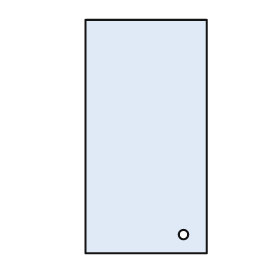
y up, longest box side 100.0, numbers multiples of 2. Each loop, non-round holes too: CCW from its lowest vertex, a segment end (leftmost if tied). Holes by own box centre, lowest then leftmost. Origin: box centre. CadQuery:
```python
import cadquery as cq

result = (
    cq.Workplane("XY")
    .moveTo(-26.0, -50.0)
    .lineTo(26.0, -50.0)
    .lineTo(26.0, 50.0)
    .lineTo(-26.0, 50.0)
    .close()
    .moveTo(16.0, -42.0)
    .circle(2.0)
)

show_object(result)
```